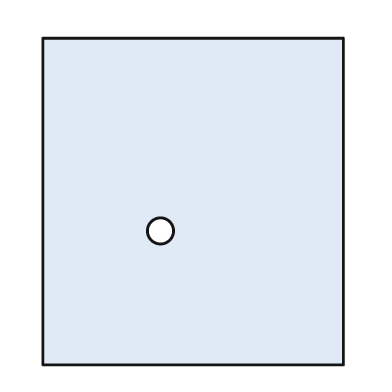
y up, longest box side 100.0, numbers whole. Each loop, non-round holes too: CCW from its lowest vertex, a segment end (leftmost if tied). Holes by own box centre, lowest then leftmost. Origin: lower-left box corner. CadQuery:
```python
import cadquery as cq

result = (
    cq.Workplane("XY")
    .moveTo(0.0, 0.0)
    .lineTo(92.0, 0.0)
    .lineTo(92.0, 100.0)
    .lineTo(0.0, 100.0)
    .close()
    .moveTo(36.0, 41.0)
    .circle(4.0)
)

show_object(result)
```